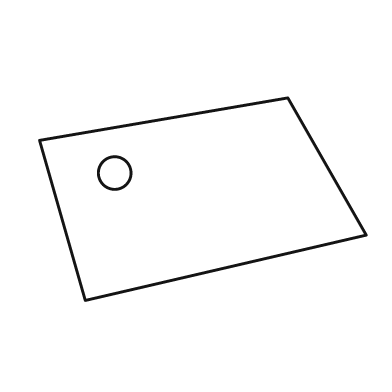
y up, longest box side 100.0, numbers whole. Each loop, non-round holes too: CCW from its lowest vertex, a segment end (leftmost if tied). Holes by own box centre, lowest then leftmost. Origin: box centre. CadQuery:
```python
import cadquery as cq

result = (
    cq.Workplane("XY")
    .moveTo(-36.0, -31.0)
    .lineTo(50.0, -11.0)
    .lineTo(26.0, 31.0)
    .lineTo(-50.0, 18.0)
    .close()
    .moveTo(-27.0, 8.0)
    .circle(5.0)
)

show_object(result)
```